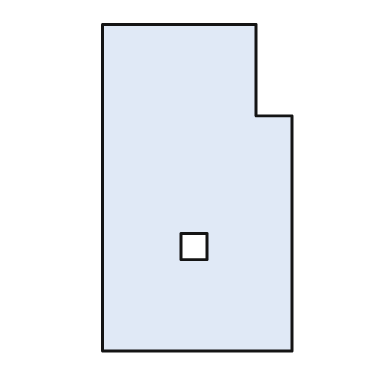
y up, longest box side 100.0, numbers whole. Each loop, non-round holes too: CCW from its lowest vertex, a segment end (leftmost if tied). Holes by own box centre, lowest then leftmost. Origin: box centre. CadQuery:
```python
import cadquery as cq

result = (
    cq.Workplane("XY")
    .moveTo(-29.0, -50.0)
    .lineTo(29.0, -50.0)
    .lineTo(29.0, 22.0)
    .lineTo(18.0, 22.0)
    .lineTo(18.0, 50.0)
    .lineTo(-29.0, 50.0)
    .close()
    .moveTo(-5.0, -22.0)
    .lineTo(3.0, -22.0)
    .lineTo(3.0, -14.0)
    .lineTo(-5.0, -14.0)
    .close()
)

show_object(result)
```